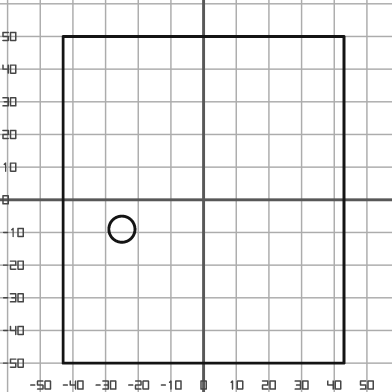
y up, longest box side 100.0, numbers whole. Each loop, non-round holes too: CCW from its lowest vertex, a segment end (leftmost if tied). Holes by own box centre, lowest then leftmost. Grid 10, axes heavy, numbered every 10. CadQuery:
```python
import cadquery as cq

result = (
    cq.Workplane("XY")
    .moveTo(-43.0, -50.0)
    .lineTo(43.0, -50.0)
    .lineTo(43.0, 50.0)
    .lineTo(-43.0, 50.0)
    .close()
    .moveTo(-25.0, -9.0)
    .circle(4.0)
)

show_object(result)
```